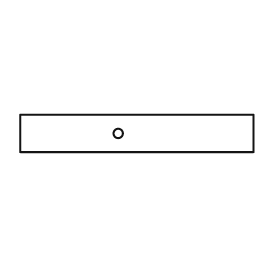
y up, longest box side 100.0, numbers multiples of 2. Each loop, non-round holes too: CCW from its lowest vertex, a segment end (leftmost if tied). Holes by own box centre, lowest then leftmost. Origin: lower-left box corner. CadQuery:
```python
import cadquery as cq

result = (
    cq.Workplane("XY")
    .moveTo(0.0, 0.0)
    .lineTo(100.0, 0.0)
    .lineTo(100.0, 16.0)
    .lineTo(0.0, 16.0)
    .close()
    .moveTo(42.0, 8.0)
    .circle(2.0)
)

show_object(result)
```